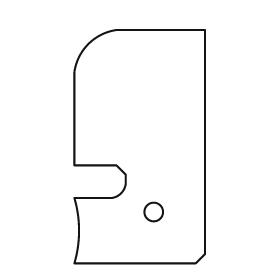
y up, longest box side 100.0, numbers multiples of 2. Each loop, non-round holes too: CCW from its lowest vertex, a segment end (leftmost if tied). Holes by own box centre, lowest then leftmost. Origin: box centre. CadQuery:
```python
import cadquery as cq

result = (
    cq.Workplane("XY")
    .moveTo(-28.0, -50.0)
    .lineTo(24.0, -50.0)
    .lineTo(28.0, -46.0)
    .lineTo(28.0, 50.0)
    .lineTo(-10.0, 50.0)
    .threePointArc((-22.0, 44.0), (-28.0, 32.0))
    .lineTo(-28.0, -8.0)
    .lineTo(-10.0, -8.0)
    .lineTo(-6.0, -12.0)
    .lineTo(-6.0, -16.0)
    .threePointArc((-8.0, -20.0), (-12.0, -22.0))
    .lineTo(-28.0, -22.0)
    .threePointArc((-26.0, -36.0), (-28.0, -50.0))
    .close()
    .moveTo(6.0, -28.0)
    .circle(4.0)
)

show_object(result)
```